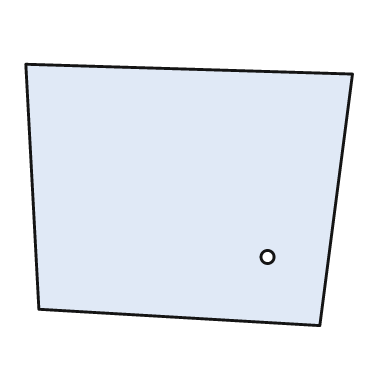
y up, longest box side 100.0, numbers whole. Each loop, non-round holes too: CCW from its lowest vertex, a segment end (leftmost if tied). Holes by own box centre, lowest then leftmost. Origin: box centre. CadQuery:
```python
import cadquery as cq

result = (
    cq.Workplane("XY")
    .moveTo(40.0, -40.0)
    .lineTo(50.0, 37.0)
    .lineTo(-50.0, 40.0)
    .lineTo(-46.0, -35.0)
    .close()
    .moveTo(24.0, -19.0)
    .circle(2.0)
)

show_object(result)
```